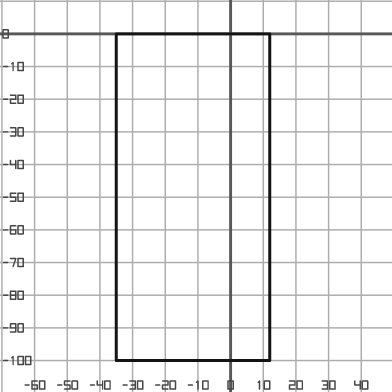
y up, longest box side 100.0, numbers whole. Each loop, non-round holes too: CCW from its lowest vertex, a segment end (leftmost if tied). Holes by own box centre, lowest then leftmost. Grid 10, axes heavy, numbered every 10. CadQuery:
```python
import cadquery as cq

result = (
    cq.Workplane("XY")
    .moveTo(-35.0, -100.0)
    .lineTo(12.0, -100.0)
    .lineTo(12.0, 0.0)
    .lineTo(-35.0, 0.0)
    .close()
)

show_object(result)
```